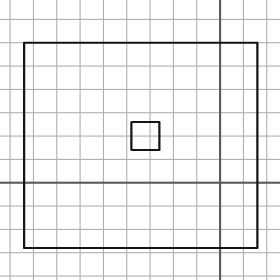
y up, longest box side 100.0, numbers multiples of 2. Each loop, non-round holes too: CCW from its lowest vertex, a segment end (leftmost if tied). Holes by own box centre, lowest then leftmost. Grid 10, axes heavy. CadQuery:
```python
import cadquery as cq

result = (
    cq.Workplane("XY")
    .moveTo(-84.0, -28.0)
    .lineTo(16.0, -28.0)
    .lineTo(16.0, 60.0)
    .lineTo(-84.0, 60.0)
    .close()
    .moveTo(-38.0, 14.0)
    .lineTo(-26.0, 14.0)
    .lineTo(-26.0, 26.0)
    .lineTo(-38.0, 26.0)
    .close()
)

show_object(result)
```